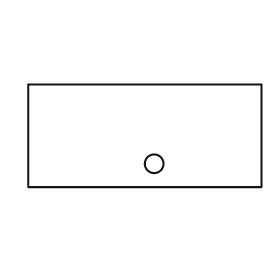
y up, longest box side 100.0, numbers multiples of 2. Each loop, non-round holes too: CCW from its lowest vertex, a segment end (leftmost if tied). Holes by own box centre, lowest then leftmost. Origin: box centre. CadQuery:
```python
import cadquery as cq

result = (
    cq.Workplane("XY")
    .moveTo(-50.0, -22.0)
    .lineTo(50.0, -22.0)
    .lineTo(50.0, 22.0)
    .lineTo(-50.0, 22.0)
    .close()
    .moveTo(4.0, -12.0)
    .circle(4.0)
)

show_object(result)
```